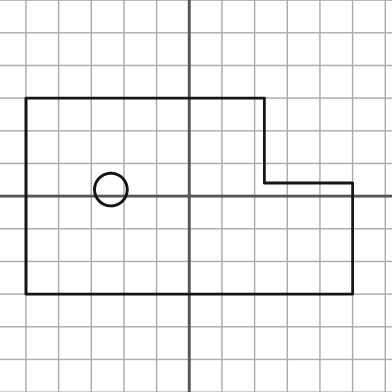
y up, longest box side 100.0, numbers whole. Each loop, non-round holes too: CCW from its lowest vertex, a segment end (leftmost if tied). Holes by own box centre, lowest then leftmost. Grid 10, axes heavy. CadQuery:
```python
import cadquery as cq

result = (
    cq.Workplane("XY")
    .moveTo(-50.0, -30.0)
    .lineTo(50.0, -30.0)
    .lineTo(50.0, 4.0)
    .lineTo(23.0, 4.0)
    .lineTo(23.0, 30.0)
    .lineTo(-50.0, 30.0)
    .close()
    .moveTo(-24.0, 2.0)
    .circle(5.0)
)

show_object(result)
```